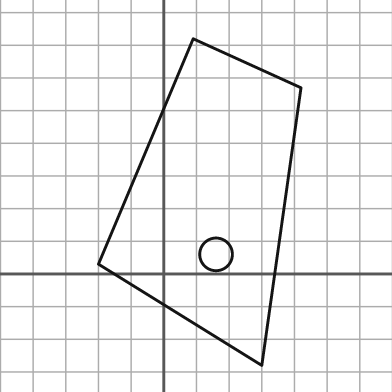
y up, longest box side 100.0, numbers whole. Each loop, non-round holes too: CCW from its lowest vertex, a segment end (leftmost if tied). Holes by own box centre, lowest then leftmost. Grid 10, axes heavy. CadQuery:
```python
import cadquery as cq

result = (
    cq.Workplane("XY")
    .moveTo(30.0, -28.0)
    .lineTo(42.0, 57.0)
    .lineTo(9.0, 72.0)
    .lineTo(-20.0, 3.0)
    .close()
    .moveTo(16.0, 6.0)
    .circle(5.0)
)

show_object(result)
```